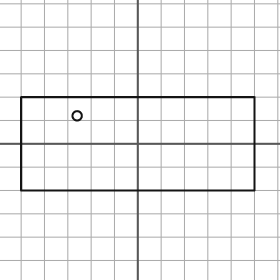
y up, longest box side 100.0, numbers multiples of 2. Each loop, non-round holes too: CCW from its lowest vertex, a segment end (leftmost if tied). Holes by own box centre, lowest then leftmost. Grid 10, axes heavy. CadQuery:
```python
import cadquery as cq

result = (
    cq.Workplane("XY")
    .moveTo(-50.0, -20.0)
    .lineTo(50.0, -20.0)
    .lineTo(50.0, 20.0)
    .lineTo(-50.0, 20.0)
    .close()
    .moveTo(-26.0, 12.0)
    .circle(2.0)
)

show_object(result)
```